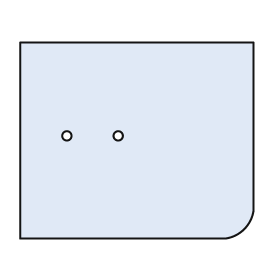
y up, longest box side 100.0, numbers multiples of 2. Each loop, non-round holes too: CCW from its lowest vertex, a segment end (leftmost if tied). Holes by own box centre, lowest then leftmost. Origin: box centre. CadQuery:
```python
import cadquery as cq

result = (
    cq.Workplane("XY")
    .moveTo(-50.0, -42.0)
    .lineTo(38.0, -42.0)
    .threePointArc((46.0, -38.0), (50.0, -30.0))
    .lineTo(50.0, 42.0)
    .lineTo(-50.0, 42.0)
    .close()
    .moveTo(-30.0, 2.0)
    .circle(2.0)
    .moveTo(-8.0, 2.0)
    .circle(2.0)
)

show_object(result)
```